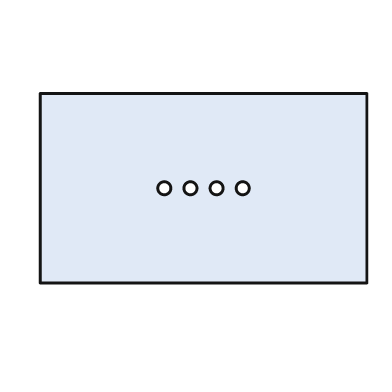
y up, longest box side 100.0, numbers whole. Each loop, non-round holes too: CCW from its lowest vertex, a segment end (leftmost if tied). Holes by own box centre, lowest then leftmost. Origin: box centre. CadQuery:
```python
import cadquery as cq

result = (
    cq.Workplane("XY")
    .moveTo(-50.0, -29.0)
    .lineTo(50.0, -29.0)
    .lineTo(50.0, 29.0)
    .lineTo(-50.0, 29.0)
    .close()
    .moveTo(-12.0, 0.0)
    .circle(2.0)
    .moveTo(-4.0, 0.0)
    .circle(2.0)
    .moveTo(4.0, 0.0)
    .circle(2.0)
    .moveTo(12.0, 0.0)
    .circle(2.0)
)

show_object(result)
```